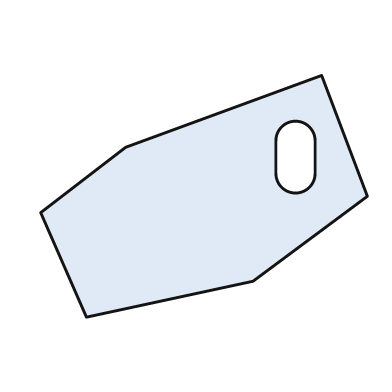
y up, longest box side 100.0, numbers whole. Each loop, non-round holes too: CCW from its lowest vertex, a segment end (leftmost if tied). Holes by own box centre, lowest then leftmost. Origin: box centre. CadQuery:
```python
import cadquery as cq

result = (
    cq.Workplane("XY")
    .moveTo(-36.0, -37.0)
    .lineTo(15.0, -26.0)
    .lineTo(50.0, 0.0)
    .lineTo(36.0, 37.0)
    .lineTo(-24.0, 15.0)
    .lineTo(-50.0, -5.0)
    .close()
    .moveTo(22.0, 7.0)
    .threePointArc((28.0, 1.0), (34.0, 7.0))
    .lineTo(34.0, 17.0)
    .threePointArc((28.0, 23.0), (22.0, 17.0))
    .close()
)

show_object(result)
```